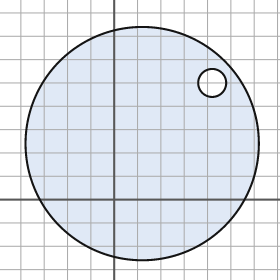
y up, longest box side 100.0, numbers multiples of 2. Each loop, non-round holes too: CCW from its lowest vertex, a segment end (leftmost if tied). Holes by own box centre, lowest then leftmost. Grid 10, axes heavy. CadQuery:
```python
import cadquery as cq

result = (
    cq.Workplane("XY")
    .moveTo(12.0, 24.0)
    .circle(50.0)
    .moveTo(42.0, 50.0)
    .circle(6.0)
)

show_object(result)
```